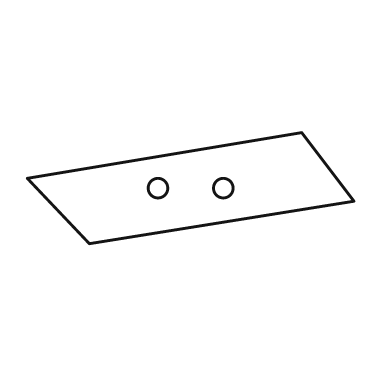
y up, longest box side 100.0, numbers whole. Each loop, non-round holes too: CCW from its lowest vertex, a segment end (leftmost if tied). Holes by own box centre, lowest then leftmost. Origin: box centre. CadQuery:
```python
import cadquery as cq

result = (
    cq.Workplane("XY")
    .moveTo(-31.0, -17.0)
    .lineTo(50.0, -4.0)
    .lineTo(34.0, 17.0)
    .lineTo(-50.0, 3.0)
    .close()
    .moveTo(-10.0, 0.0)
    .circle(3.0)
    .moveTo(10.0, 0.0)
    .circle(3.0)
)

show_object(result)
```